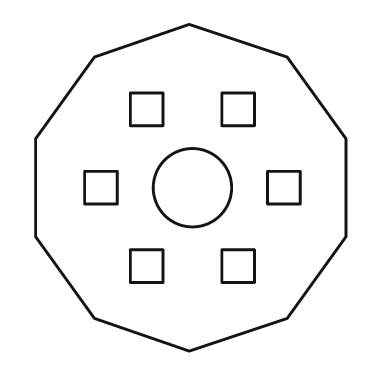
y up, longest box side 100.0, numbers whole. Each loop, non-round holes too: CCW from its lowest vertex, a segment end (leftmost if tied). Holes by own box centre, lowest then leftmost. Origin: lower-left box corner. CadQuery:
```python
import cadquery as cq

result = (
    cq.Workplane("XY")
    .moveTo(47.0, 0.0)
    .lineTo(77.0, 10.0)
    .lineTo(95.0, 35.0)
    .lineTo(95.0, 65.0)
    .lineTo(77.0, 90.0)
    .lineTo(47.0, 100.0)
    .lineTo(18.0, 90.0)
    .lineTo(0.0, 65.0)
    .lineTo(0.0, 35.0)
    .lineTo(18.0, 10.0)
    .close()
    .moveTo(29.0, 21.0)
    .lineTo(39.0, 21.0)
    .lineTo(39.0, 31.0)
    .lineTo(29.0, 31.0)
    .close()
    .moveTo(57.0, 21.0)
    .lineTo(67.0, 21.0)
    .lineTo(67.0, 31.0)
    .lineTo(57.0, 31.0)
    .close()
    .moveTo(15.0, 45.0)
    .lineTo(25.0, 45.0)
    .lineTo(25.0, 55.0)
    .lineTo(15.0, 55.0)
    .close()
    .moveTo(48.0, 50.0)
    .circle(12.0)
    .moveTo(71.0, 45.0)
    .lineTo(81.0, 45.0)
    .lineTo(81.0, 55.0)
    .lineTo(71.0, 55.0)
    .close()
    .moveTo(29.0, 69.0)
    .lineTo(39.0, 69.0)
    .lineTo(39.0, 79.0)
    .lineTo(29.0, 79.0)
    .close()
    .moveTo(57.0, 69.0)
    .lineTo(67.0, 69.0)
    .lineTo(67.0, 79.0)
    .lineTo(57.0, 79.0)
    .close()
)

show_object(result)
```